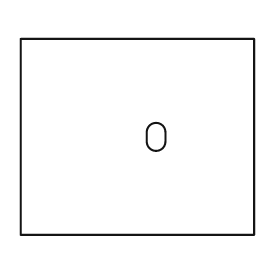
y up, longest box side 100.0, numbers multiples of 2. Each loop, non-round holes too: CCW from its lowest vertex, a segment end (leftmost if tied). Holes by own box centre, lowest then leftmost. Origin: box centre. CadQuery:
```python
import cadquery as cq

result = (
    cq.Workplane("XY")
    .moveTo(-50.0, -42.0)
    .lineTo(50.0, -42.0)
    .lineTo(50.0, 42.0)
    .lineTo(-50.0, 42.0)
    .close()
    .moveTo(4.0, -2.0)
    .threePointArc((8.0, -6.0), (12.0, -2.0))
    .lineTo(12.0, 2.0)
    .threePointArc((8.0, 6.0), (4.0, 2.0))
    .close()
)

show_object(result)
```